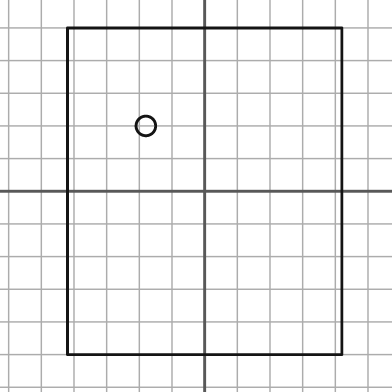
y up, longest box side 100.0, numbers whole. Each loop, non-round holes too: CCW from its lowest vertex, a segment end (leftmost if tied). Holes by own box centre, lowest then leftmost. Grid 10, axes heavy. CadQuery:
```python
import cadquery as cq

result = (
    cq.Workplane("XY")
    .moveTo(-42.0, -50.0)
    .lineTo(42.0, -50.0)
    .lineTo(42.0, 50.0)
    .lineTo(-42.0, 50.0)
    .close()
    .moveTo(-18.0, 20.0)
    .circle(3.0)
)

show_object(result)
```